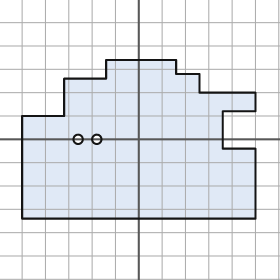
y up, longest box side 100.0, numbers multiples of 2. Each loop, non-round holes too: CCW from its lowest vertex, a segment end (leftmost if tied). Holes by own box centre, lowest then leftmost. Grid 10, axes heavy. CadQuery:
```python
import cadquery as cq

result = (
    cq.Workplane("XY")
    .moveTo(-50.0, -34.0)
    .lineTo(50.0, -34.0)
    .lineTo(50.0, -4.0)
    .lineTo(36.0, -4.0)
    .lineTo(36.0, 12.0)
    .lineTo(50.0, 12.0)
    .lineTo(50.0, 20.0)
    .lineTo(26.0, 20.0)
    .lineTo(26.0, 28.0)
    .lineTo(16.0, 28.0)
    .lineTo(16.0, 34.0)
    .lineTo(-14.0, 34.0)
    .lineTo(-14.0, 26.0)
    .lineTo(-32.0, 26.0)
    .lineTo(-32.0, 10.0)
    .lineTo(-50.0, 10.0)
    .close()
    .moveTo(-26.0, 0.0)
    .circle(2.0)
    .moveTo(-18.0, 0.0)
    .circle(2.0)
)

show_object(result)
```